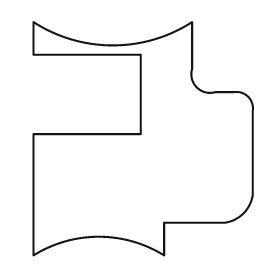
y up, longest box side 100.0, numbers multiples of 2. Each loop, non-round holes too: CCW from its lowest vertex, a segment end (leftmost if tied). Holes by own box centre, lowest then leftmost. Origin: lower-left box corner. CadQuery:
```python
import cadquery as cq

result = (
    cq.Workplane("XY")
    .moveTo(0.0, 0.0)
    .threePointArc((28.0, 8.0), (56.0, 0.0))
    .lineTo(56.0, 14.0)
    .lineTo(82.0, 14.0)
    .threePointArc((90.0, 18.0), (94.0, 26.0))
    .lineTo(94.0, 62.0)
    .threePointArc((92.0, 68.0), (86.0, 70.0))
    .lineTo(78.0, 70.0)
    .threePointArc((70.0, 72.0), (68.0, 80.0))
    .lineTo(68.0, 100.0)
    .threePointArc((34.0, 90.0), (0.0, 100.0))
    .lineTo(0.0, 86.0)
    .lineTo(46.0, 86.0)
    .lineTo(46.0, 52.0)
    .lineTo(0.0, 52.0)
    .close()
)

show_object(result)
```